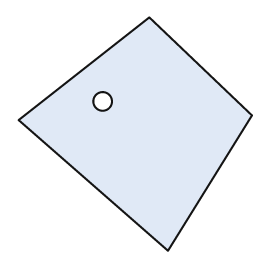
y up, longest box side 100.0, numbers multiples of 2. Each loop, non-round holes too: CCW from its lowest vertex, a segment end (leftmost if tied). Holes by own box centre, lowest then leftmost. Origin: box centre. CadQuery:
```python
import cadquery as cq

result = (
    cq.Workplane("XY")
    .moveTo(14.0, -50.0)
    .lineTo(50.0, 8.0)
    .lineTo(6.0, 50.0)
    .lineTo(-50.0, 6.0)
    .close()
    .moveTo(-14.0, 14.0)
    .circle(4.0)
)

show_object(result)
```